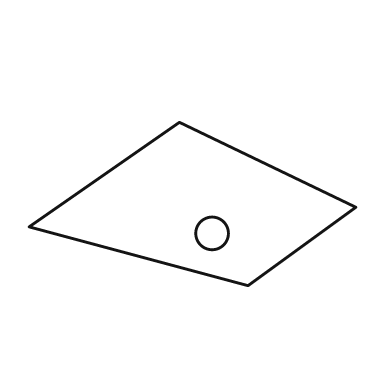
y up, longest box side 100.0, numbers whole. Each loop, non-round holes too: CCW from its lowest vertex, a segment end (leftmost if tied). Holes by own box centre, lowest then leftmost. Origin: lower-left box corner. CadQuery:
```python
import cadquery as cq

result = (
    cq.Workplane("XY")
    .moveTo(67.0, 0.0)
    .lineTo(100.0, 24.0)
    .lineTo(46.0, 50.0)
    .lineTo(0.0, 18.0)
    .close()
    .moveTo(56.0, 16.0)
    .circle(5.0)
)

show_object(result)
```